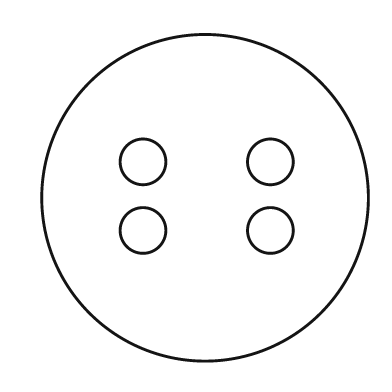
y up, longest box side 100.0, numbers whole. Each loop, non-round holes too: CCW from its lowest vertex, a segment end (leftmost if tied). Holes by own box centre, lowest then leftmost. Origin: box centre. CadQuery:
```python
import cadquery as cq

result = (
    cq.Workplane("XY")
    .moveTo(0.0, 0.0)
    .circle(50.0)
    .moveTo(-19.0, -10.0)
    .circle(7.0)
    .moveTo(20.0, -10.0)
    .circle(7.0)
    .moveTo(-19.0, 11.0)
    .circle(7.0)
    .moveTo(20.0, 11.0)
    .circle(7.0)
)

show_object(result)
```